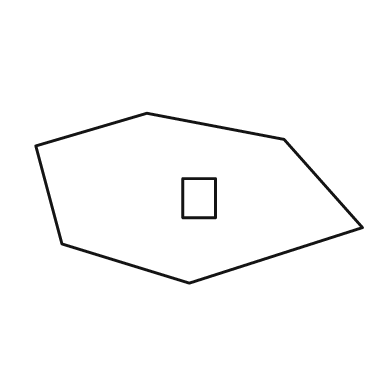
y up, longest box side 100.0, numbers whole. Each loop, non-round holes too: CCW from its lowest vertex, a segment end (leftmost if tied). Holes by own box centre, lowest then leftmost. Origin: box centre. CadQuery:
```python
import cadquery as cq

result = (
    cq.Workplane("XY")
    .moveTo(-3.0, -26.0)
    .lineTo(50.0, -9.0)
    .lineTo(26.0, 18.0)
    .lineTo(-16.0, 26.0)
    .lineTo(-50.0, 16.0)
    .lineTo(-42.0, -14.0)
    .close()
    .moveTo(-5.0, -6.0)
    .lineTo(5.0, -6.0)
    .lineTo(5.0, 6.0)
    .lineTo(-5.0, 6.0)
    .close()
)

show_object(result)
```